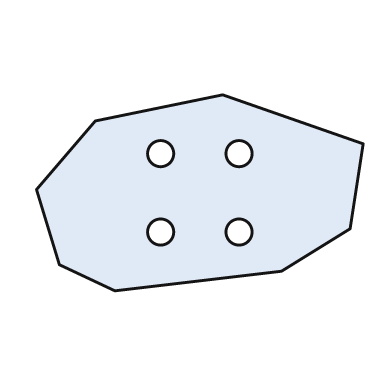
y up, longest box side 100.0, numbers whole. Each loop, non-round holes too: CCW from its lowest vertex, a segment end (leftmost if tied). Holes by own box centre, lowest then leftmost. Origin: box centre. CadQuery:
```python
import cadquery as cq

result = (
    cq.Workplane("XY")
    .moveTo(-26.0, -30.0)
    .lineTo(25.0, -24.0)
    .lineTo(46.0, -11.0)
    .lineTo(50.0, 15.0)
    .lineTo(7.0, 30.0)
    .lineTo(-32.0, 22.0)
    .lineTo(-50.0, 1.0)
    .lineTo(-43.0, -22.0)
    .close()
    .moveTo(-12.0, -12.0)
    .circle(4.0)
    .moveTo(12.0, -12.0)
    .circle(4.0)
    .moveTo(-12.0, 12.0)
    .circle(4.0)
    .moveTo(12.0, 12.0)
    .circle(4.0)
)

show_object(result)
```